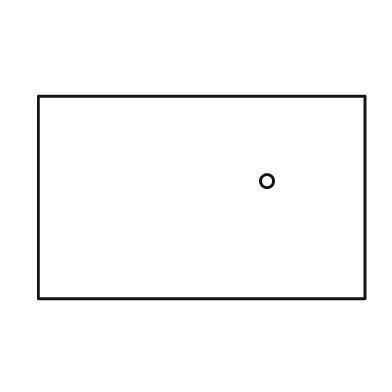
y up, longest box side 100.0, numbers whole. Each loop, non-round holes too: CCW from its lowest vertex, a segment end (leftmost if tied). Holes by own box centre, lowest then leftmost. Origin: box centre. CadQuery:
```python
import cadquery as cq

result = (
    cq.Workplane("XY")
    .moveTo(-50.0, -31.0)
    .lineTo(50.0, -31.0)
    .lineTo(50.0, 31.0)
    .lineTo(-50.0, 31.0)
    .close()
    .moveTo(20.0, 5.0)
    .circle(2.0)
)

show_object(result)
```